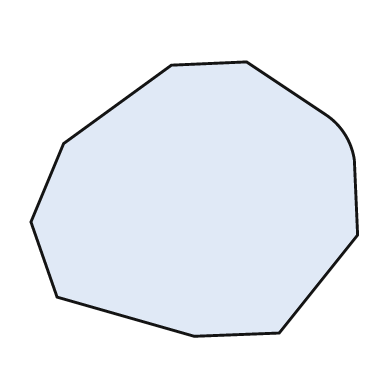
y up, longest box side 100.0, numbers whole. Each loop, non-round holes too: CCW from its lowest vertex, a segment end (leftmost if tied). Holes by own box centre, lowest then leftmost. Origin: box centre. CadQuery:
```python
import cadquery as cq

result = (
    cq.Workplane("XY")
    .moveTo(0.0, -42.0)
    .lineTo(26.0, -41.0)
    .lineTo(50.0, -11.0)
    .lineTo(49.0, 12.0)
    .threePointArc((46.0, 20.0), (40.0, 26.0))
    .lineTo(16.0, 42.0)
    .lineTo(-7.0, 41.0)
    .lineTo(-40.0, 17.0)
    .lineTo(-50.0, -7.0)
    .lineTo(-42.0, -30.0)
    .close()
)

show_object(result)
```